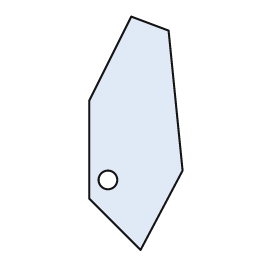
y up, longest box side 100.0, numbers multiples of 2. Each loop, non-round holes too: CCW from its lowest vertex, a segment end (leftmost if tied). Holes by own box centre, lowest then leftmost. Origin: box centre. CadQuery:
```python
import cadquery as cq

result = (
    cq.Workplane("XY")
    .moveTo(2.0, -50.0)
    .lineTo(20.0, -16.0)
    .lineTo(14.0, 44.0)
    .lineTo(-2.0, 50.0)
    .lineTo(-20.0, 14.0)
    .lineTo(-20.0, -28.0)
    .close()
    .moveTo(-12.0, -20.0)
    .circle(4.0)
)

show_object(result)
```